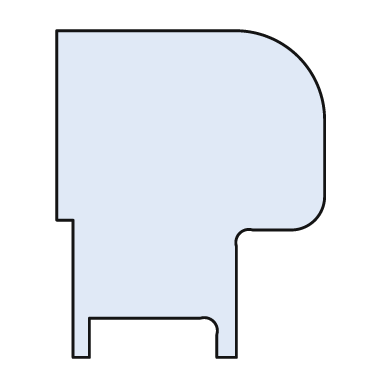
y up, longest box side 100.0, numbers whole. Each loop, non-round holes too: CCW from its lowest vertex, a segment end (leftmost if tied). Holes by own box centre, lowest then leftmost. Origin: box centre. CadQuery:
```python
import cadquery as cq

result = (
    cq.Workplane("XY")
    .moveTo(-36.0, -50.0)
    .lineTo(-31.0, -50.0)
    .lineTo(-31.0, -38.0)
    .lineTo(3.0, -38.0)
    .threePointArc((7.0, -39.0), (8.0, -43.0))
    .lineTo(8.0, -50.0)
    .lineTo(14.0, -50.0)
    .lineTo(14.0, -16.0)
    .threePointArc((15.0, -12.0), (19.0, -11.0))
    .lineTo(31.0, -11.0)
    .threePointArc((38.0, -8.0), (41.0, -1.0))
    .lineTo(41.0, 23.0)
    .threePointArc((33.0, 42.0), (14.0, 50.0))
    .lineTo(-41.0, 50.0)
    .lineTo(-41.0, -8.0)
    .lineTo(-36.0, -8.0)
    .close()
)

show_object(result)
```